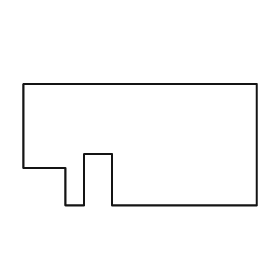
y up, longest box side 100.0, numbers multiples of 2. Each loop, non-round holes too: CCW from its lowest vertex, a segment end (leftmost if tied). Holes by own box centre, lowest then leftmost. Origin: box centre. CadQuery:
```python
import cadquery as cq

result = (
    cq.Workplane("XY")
    .moveTo(-32.0, -26.0)
    .lineTo(-24.0, -26.0)
    .lineTo(-24.0, -4.0)
    .lineTo(-12.0, -4.0)
    .lineTo(-12.0, -26.0)
    .lineTo(50.0, -26.0)
    .lineTo(50.0, 26.0)
    .lineTo(-50.0, 26.0)
    .lineTo(-50.0, -10.0)
    .lineTo(-32.0, -10.0)
    .close()
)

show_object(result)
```